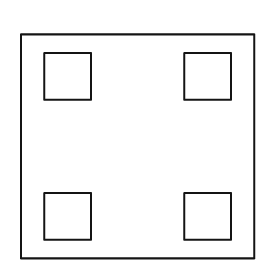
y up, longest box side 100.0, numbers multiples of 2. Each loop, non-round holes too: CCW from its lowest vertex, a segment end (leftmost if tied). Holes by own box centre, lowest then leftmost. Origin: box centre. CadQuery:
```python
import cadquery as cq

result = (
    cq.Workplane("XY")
    .moveTo(-50.0, -48.0)
    .lineTo(50.0, -48.0)
    .lineTo(50.0, 48.0)
    .lineTo(-50.0, 48.0)
    .close()
    .moveTo(-40.0, -40.0)
    .lineTo(-20.0, -40.0)
    .lineTo(-20.0, -20.0)
    .lineTo(-40.0, -20.0)
    .close()
    .moveTo(20.0, -40.0)
    .lineTo(40.0, -40.0)
    .lineTo(40.0, -20.0)
    .lineTo(20.0, -20.0)
    .close()
    .moveTo(-40.0, 20.0)
    .lineTo(-20.0, 20.0)
    .lineTo(-20.0, 40.0)
    .lineTo(-40.0, 40.0)
    .close()
    .moveTo(20.0, 20.0)
    .lineTo(40.0, 20.0)
    .lineTo(40.0, 40.0)
    .lineTo(20.0, 40.0)
    .close()
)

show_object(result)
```